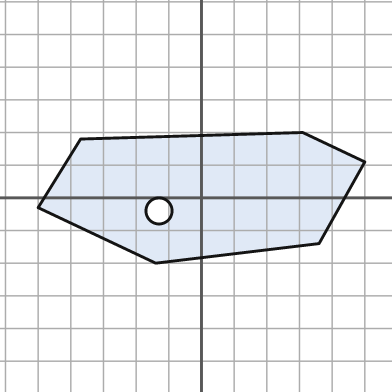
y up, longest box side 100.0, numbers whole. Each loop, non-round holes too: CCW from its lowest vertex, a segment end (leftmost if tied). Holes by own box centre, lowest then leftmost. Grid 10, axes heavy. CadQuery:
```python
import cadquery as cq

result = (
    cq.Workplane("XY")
    .moveTo(-14.0, -20.0)
    .lineTo(36.0, -14.0)
    .lineTo(50.0, 11.0)
    .lineTo(31.0, 20.0)
    .lineTo(-37.0, 18.0)
    .lineTo(-50.0, -3.0)
    .close()
    .moveTo(-13.0, -4.0)
    .circle(4.0)
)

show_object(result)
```